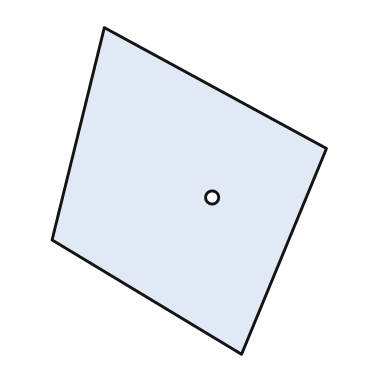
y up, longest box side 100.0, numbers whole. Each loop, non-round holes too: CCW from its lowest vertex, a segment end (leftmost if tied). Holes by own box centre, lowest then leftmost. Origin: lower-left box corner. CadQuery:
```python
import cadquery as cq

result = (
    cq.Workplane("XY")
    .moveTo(58.0, 0.0)
    .lineTo(84.0, 63.0)
    .lineTo(16.0, 100.0)
    .lineTo(0.0, 35.0)
    .close()
    .moveTo(49.0, 48.0)
    .circle(2.0)
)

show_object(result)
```